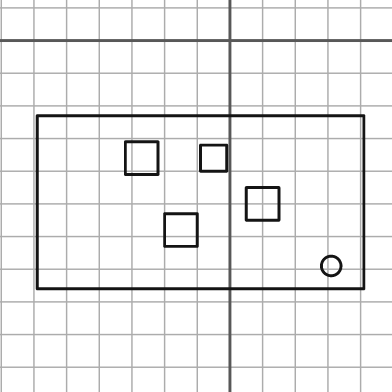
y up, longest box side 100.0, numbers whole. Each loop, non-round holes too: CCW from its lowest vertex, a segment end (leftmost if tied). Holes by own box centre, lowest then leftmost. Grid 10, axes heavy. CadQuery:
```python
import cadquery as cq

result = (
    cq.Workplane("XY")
    .moveTo(-59.0, -76.0)
    .lineTo(41.0, -76.0)
    .lineTo(41.0, -23.0)
    .lineTo(-59.0, -23.0)
    .close()
    .moveTo(31.0, -69.0)
    .circle(3.0)
    .moveTo(-20.0, -63.0)
    .lineTo(-10.0, -63.0)
    .lineTo(-10.0, -53.0)
    .lineTo(-20.0, -53.0)
    .close()
    .moveTo(5.0, -55.0)
    .lineTo(15.0, -55.0)
    .lineTo(15.0, -45.0)
    .lineTo(5.0, -45.0)
    .close()
    .moveTo(-32.0, -41.0)
    .lineTo(-22.0, -41.0)
    .lineTo(-22.0, -31.0)
    .lineTo(-32.0, -31.0)
    .close()
    .moveTo(-9.0, -40.0)
    .lineTo(-1.0, -40.0)
    .lineTo(-1.0, -32.0)
    .lineTo(-9.0, -32.0)
    .close()
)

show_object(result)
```